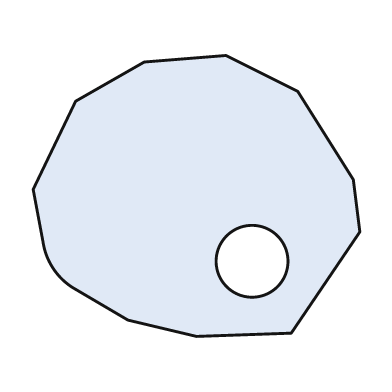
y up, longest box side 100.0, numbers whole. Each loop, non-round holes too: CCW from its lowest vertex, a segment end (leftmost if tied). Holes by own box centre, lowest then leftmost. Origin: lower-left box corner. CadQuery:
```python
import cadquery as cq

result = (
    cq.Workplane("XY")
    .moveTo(50.0, 0.0)
    .lineTo(79.0, 1.0)
    .lineTo(100.0, 32.0)
    .lineTo(98.0, 48.0)
    .lineTo(81.0, 75.0)
    .lineTo(59.0, 86.0)
    .lineTo(34.0, 84.0)
    .lineTo(13.0, 72.0)
    .lineTo(0.0, 45.0)
    .lineTo(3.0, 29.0)
    .threePointArc((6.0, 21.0), (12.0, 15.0))
    .lineTo(29.0, 5.0)
    .close()
    .moveTo(67.0, 23.0)
    .circle(11.0)
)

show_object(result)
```